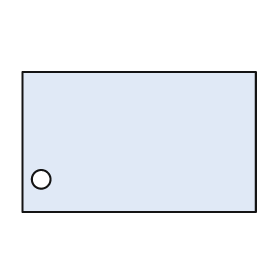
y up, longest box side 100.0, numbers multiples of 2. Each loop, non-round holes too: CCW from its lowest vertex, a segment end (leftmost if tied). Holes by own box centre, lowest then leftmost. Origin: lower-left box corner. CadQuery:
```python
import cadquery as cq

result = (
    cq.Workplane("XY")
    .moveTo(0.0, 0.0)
    .lineTo(100.0, 0.0)
    .lineTo(100.0, 60.0)
    .lineTo(0.0, 60.0)
    .close()
    .moveTo(8.0, 14.0)
    .circle(4.0)
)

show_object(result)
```